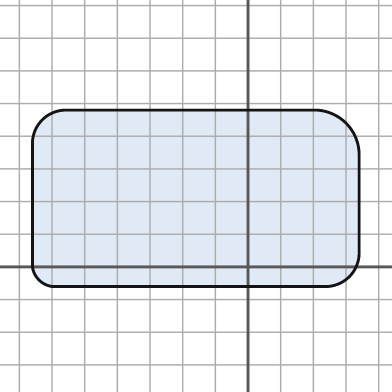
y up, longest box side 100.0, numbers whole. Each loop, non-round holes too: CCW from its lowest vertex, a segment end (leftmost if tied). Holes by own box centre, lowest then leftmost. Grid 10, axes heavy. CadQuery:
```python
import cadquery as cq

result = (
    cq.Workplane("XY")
    .moveTo(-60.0, -6.0)
    .lineTo(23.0, -6.0)
    .threePointArc((31.0, -3.0), (34.0, 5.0))
    .lineTo(34.0, 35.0)
    .threePointArc((30.0, 44.0), (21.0, 48.0))
    .lineTo(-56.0, 48.0)
    .threePointArc((-63.0, 45.0), (-66.0, 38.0))
    .lineTo(-66.0, 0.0)
    .threePointArc((-64.0, -4.0), (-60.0, -6.0))
    .close()
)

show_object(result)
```